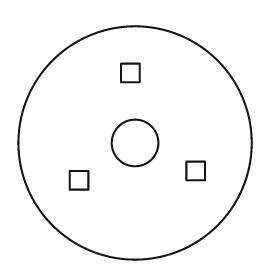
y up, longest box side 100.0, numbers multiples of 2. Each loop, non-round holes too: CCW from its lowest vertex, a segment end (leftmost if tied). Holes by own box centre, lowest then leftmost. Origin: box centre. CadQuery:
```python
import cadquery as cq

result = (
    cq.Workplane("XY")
    .moveTo(0.0, 0.0)
    .circle(50.0)
    .moveTo(-28.0, -20.0)
    .lineTo(-20.0, -20.0)
    .lineTo(-20.0, -12.0)
    .lineTo(-28.0, -12.0)
    .close()
    .moveTo(22.0, -16.0)
    .lineTo(30.0, -16.0)
    .lineTo(30.0, -8.0)
    .lineTo(22.0, -8.0)
    .close()
    .moveTo(0.0, 0.0)
    .circle(10.0)
    .moveTo(-6.0, 26.0)
    .lineTo(2.0, 26.0)
    .lineTo(2.0, 34.0)
    .lineTo(-6.0, 34.0)
    .close()
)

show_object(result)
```